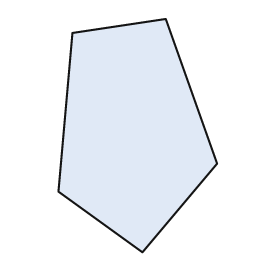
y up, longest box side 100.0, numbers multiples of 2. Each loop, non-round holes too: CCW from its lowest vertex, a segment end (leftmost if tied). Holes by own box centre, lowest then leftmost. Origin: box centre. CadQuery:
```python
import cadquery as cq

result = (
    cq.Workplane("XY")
    .moveTo(2.0, -50.0)
    .lineTo(34.0, -12.0)
    .lineTo(12.0, 50.0)
    .lineTo(-28.0, 44.0)
    .lineTo(-34.0, -24.0)
    .close()
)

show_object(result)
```